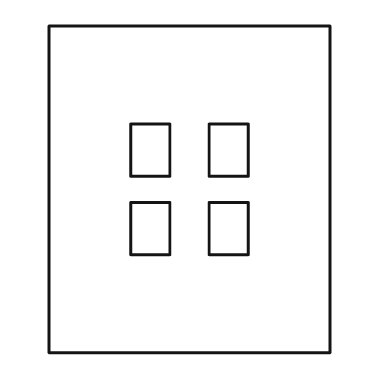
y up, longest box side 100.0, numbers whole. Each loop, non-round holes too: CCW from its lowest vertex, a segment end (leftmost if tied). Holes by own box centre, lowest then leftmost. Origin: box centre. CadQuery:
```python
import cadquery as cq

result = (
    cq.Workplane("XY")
    .moveTo(-43.0, -50.0)
    .lineTo(43.0, -50.0)
    .lineTo(43.0, 50.0)
    .lineTo(-43.0, 50.0)
    .close()
    .moveTo(-18.0, -20.0)
    .lineTo(-6.0, -20.0)
    .lineTo(-6.0, -4.0)
    .lineTo(-18.0, -4.0)
    .close()
    .moveTo(6.0, -20.0)
    .lineTo(18.0, -20.0)
    .lineTo(18.0, -4.0)
    .lineTo(6.0, -4.0)
    .close()
    .moveTo(-18.0, 4.0)
    .lineTo(-6.0, 4.0)
    .lineTo(-6.0, 20.0)
    .lineTo(-18.0, 20.0)
    .close()
    .moveTo(6.0, 4.0)
    .lineTo(18.0, 4.0)
    .lineTo(18.0, 20.0)
    .lineTo(6.0, 20.0)
    .close()
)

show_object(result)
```